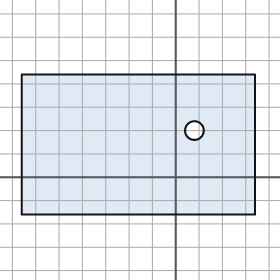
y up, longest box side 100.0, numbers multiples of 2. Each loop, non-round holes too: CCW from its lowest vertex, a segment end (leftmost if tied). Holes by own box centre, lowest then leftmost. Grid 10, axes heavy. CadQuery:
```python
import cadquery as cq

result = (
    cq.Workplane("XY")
    .moveTo(-66.0, -16.0)
    .lineTo(34.0, -16.0)
    .lineTo(34.0, 44.0)
    .lineTo(-66.0, 44.0)
    .close()
    .moveTo(8.0, 20.0)
    .circle(4.0)
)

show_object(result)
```